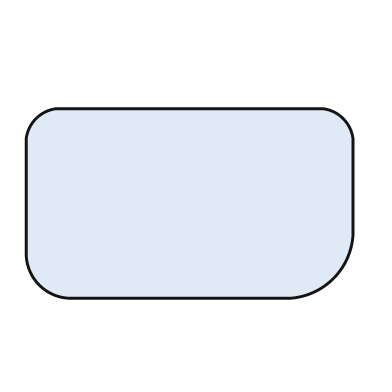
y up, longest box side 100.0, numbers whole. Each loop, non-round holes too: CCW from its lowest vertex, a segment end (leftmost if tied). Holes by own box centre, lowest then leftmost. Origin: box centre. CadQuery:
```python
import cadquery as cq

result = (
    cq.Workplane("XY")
    .moveTo(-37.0, -29.0)
    .lineTo(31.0, -29.0)
    .threePointArc((44.0, -23.0), (50.0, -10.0))
    .lineTo(50.0, 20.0)
    .threePointArc((47.0, 26.0), (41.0, 29.0))
    .lineTo(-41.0, 29.0)
    .threePointArc((-47.0, 26.0), (-50.0, 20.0))
    .lineTo(-50.0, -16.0)
    .threePointArc((-46.0, -25.0), (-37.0, -29.0))
    .close()
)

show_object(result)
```